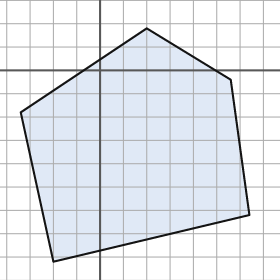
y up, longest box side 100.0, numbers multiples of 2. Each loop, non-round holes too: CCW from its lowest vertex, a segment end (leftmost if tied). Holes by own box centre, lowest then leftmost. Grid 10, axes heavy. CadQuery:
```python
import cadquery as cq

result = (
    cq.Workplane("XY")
    .moveTo(-20.0, -82.0)
    .lineTo(64.0, -62.0)
    .lineTo(56.0, -4.0)
    .lineTo(20.0, 18.0)
    .lineTo(-34.0, -18.0)
    .close()
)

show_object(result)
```